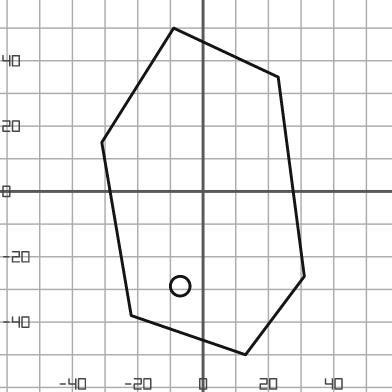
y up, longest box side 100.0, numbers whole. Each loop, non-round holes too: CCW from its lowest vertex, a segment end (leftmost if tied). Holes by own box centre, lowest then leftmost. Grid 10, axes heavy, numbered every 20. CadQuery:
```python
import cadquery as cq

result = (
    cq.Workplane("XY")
    .moveTo(13.0, -50.0)
    .lineTo(31.0, -26.0)
    .lineTo(23.0, 35.0)
    .lineTo(-9.0, 50.0)
    .lineTo(-31.0, 15.0)
    .lineTo(-22.0, -38.0)
    .close()
    .moveTo(-7.0, -29.0)
    .circle(3.0)
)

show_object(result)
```